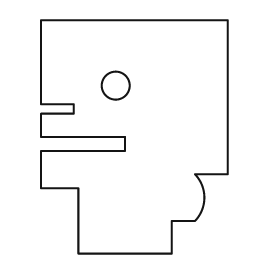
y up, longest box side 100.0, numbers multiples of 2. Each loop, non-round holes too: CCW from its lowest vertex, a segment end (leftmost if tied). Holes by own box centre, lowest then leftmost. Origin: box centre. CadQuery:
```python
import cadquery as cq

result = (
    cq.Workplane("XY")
    .moveTo(-24.0, -50.0)
    .lineTo(16.0, -50.0)
    .lineTo(16.0, -36.0)
    .lineTo(26.0, -36.0)
    .threePointArc((30.0, -26.0), (26.0, -16.0))
    .lineTo(40.0, -16.0)
    .lineTo(40.0, 50.0)
    .lineTo(-40.0, 50.0)
    .lineTo(-40.0, 14.0)
    .lineTo(-26.0, 14.0)
    .lineTo(-26.0, 10.0)
    .lineTo(-40.0, 10.0)
    .lineTo(-40.0, 0.0)
    .lineTo(-4.0, 0.0)
    .lineTo(-4.0, -6.0)
    .lineTo(-40.0, -6.0)
    .lineTo(-40.0, -22.0)
    .lineTo(-24.0, -22.0)
    .close()
    .moveTo(-8.0, 22.0)
    .circle(6.0)
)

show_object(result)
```